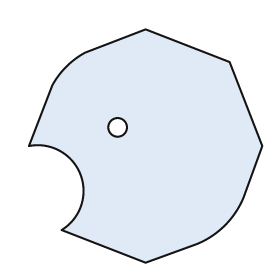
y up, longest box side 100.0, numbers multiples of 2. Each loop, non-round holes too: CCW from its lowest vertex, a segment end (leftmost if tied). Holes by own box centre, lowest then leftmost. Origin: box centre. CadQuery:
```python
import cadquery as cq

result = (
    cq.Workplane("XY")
    .moveTo(0.0, -50.0)
    .lineTo(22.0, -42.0)
    .threePointArc((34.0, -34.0), (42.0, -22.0))
    .lineTo(50.0, 0.0)
    .lineTo(36.0, 36.0)
    .lineTo(0.0, 50.0)
    .lineTo(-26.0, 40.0)
    .threePointArc((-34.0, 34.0), (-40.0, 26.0))
    .lineTo(-50.0, 0.0)
    .threePointArc((-28.0, -12.0), (-36.0, -36.0))
    .close()
    .moveTo(-12.0, 8.0)
    .circle(4.0)
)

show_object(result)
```